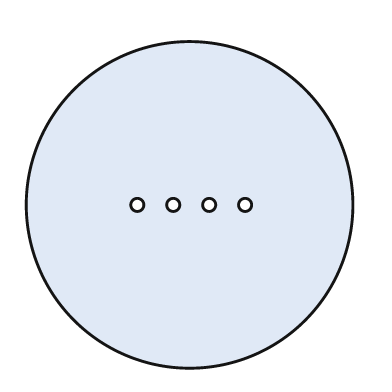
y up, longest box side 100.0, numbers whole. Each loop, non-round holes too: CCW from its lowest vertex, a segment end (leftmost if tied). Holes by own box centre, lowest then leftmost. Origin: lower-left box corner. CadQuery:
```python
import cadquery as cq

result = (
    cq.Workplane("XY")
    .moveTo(50.0, 50.0)
    .circle(50.0)
    .moveTo(34.0, 50.0)
    .circle(2.0)
    .moveTo(45.0, 50.0)
    .circle(2.0)
    .moveTo(56.0, 50.0)
    .circle(2.0)
    .moveTo(67.0, 50.0)
    .circle(2.0)
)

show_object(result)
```